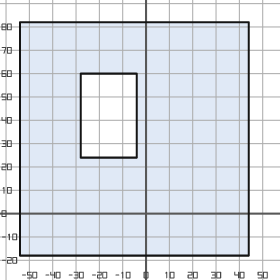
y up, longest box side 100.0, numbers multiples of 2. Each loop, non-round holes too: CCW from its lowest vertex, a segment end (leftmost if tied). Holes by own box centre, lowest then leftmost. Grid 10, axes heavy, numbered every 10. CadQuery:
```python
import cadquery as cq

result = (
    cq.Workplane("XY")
    .moveTo(-54.0, -18.0)
    .lineTo(44.0, -18.0)
    .lineTo(44.0, 82.0)
    .lineTo(-54.0, 82.0)
    .close()
    .moveTo(-28.0, 24.0)
    .lineTo(-4.0, 24.0)
    .lineTo(-4.0, 60.0)
    .lineTo(-28.0, 60.0)
    .close()
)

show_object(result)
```